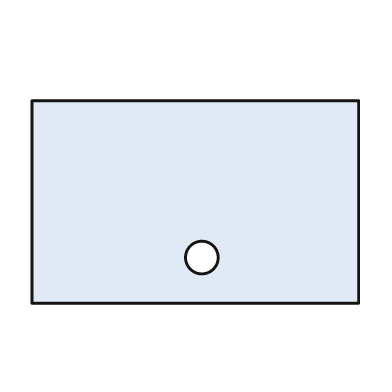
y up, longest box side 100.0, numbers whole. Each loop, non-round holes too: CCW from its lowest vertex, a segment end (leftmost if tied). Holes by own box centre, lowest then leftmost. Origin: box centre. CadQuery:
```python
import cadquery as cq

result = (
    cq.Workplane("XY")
    .moveTo(-50.0, -31.0)
    .lineTo(50.0, -31.0)
    .lineTo(50.0, 31.0)
    .lineTo(-50.0, 31.0)
    .close()
    .moveTo(2.0, -17.0)
    .circle(5.0)
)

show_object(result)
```